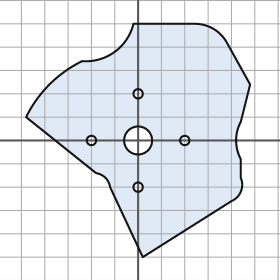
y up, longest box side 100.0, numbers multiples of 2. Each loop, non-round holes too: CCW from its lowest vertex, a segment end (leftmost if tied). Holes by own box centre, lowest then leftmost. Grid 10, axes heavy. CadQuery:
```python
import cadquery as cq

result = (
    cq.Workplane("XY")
    .moveTo(2.0, -50.0)
    .lineTo(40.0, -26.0)
    .threePointArc((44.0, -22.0), (44.0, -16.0))
    .lineTo(44.0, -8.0)
    .threePointArc((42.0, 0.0), (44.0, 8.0))
    .lineTo(48.0, 24.0)
    .lineTo(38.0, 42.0)
    .threePointArc((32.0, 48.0), (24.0, 50.0))
    .lineTo(-2.0, 50.0)
    .threePointArc((-10.0, 38.0), (-24.0, 34.0))
    .threePointArc((-38.0, 24.0), (-48.0, 10.0))
    .lineTo(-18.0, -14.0)
    .threePointArc((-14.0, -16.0), (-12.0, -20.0))
    .close()
    .moveTo(0.0, -20.0)
    .circle(2.0)
    .moveTo(-20.0, 0.0)
    .circle(2.0)
    .moveTo(0.0, 0.0)
    .circle(6.0)
    .moveTo(20.0, 0.0)
    .circle(2.0)
    .moveTo(0.0, 20.0)
    .circle(2.0)
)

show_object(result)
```